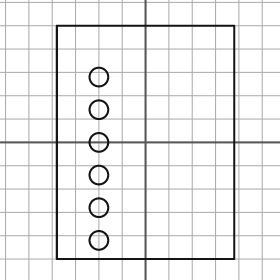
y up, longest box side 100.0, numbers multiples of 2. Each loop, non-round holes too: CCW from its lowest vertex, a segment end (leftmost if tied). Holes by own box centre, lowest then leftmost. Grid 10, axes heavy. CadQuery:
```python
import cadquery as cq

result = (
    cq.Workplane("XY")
    .moveTo(-38.0, -50.0)
    .lineTo(38.0, -50.0)
    .lineTo(38.0, 50.0)
    .lineTo(-38.0, 50.0)
    .close()
    .moveTo(-20.0, -42.0)
    .circle(4.0)
    .moveTo(-20.0, -28.0)
    .circle(4.0)
    .moveTo(-20.0, -14.0)
    .circle(4.0)
    .moveTo(-20.0, 0.0)
    .circle(4.0)
    .moveTo(-20.0, 14.0)
    .circle(4.0)
    .moveTo(-20.0, 28.0)
    .circle(4.0)
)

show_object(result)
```